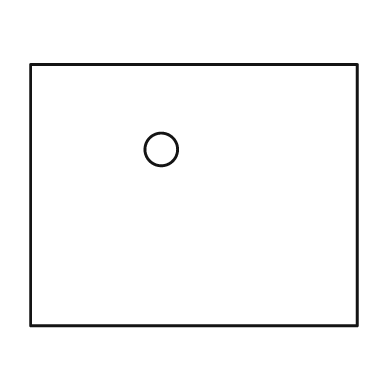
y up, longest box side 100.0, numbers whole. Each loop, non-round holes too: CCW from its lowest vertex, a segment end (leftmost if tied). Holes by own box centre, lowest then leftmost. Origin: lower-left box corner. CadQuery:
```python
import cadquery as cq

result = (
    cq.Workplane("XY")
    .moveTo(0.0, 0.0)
    .lineTo(100.0, 0.0)
    .lineTo(100.0, 80.0)
    .lineTo(0.0, 80.0)
    .close()
    .moveTo(40.0, 54.0)
    .circle(5.0)
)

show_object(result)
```